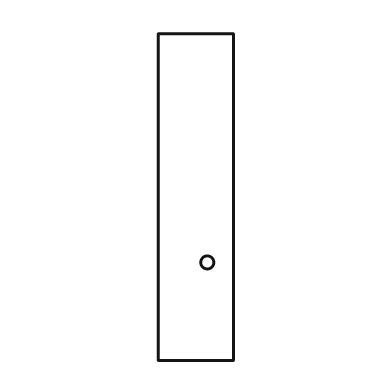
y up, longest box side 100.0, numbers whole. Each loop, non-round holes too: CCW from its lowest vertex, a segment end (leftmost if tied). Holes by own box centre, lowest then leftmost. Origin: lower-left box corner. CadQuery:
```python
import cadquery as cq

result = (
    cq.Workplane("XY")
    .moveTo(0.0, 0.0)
    .lineTo(23.0, 0.0)
    .lineTo(23.0, 100.0)
    .lineTo(0.0, 100.0)
    .close()
    .moveTo(15.0, 30.0)
    .circle(2.0)
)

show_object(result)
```